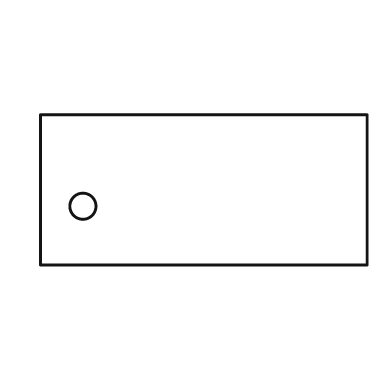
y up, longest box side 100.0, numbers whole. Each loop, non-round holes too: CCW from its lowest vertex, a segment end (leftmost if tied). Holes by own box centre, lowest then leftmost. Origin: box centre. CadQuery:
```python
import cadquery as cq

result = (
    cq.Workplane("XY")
    .moveTo(-50.0, -23.0)
    .lineTo(50.0, -23.0)
    .lineTo(50.0, 23.0)
    .lineTo(-50.0, 23.0)
    .close()
    .moveTo(-37.0, -5.0)
    .circle(4.0)
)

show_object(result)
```